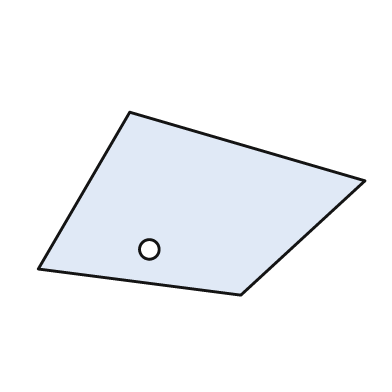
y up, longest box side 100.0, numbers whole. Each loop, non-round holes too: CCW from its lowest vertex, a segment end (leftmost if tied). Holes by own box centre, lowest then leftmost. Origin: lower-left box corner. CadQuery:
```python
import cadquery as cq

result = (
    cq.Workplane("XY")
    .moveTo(62.0, 0.0)
    .lineTo(100.0, 35.0)
    .lineTo(28.0, 56.0)
    .lineTo(0.0, 8.0)
    .close()
    .moveTo(34.0, 14.0)
    .circle(3.0)
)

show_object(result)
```